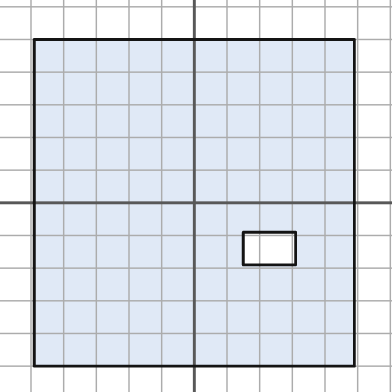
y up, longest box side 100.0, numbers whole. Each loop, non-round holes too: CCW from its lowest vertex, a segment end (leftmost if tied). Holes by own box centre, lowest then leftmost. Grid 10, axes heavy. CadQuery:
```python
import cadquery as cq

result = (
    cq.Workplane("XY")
    .moveTo(-49.0, -50.0)
    .lineTo(49.0, -50.0)
    .lineTo(49.0, 50.0)
    .lineTo(-49.0, 50.0)
    .close()
    .moveTo(15.0, -19.0)
    .lineTo(31.0, -19.0)
    .lineTo(31.0, -9.0)
    .lineTo(15.0, -9.0)
    .close()
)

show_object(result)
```